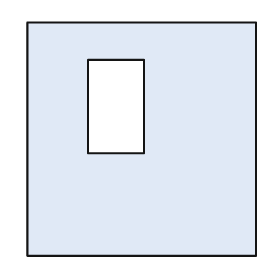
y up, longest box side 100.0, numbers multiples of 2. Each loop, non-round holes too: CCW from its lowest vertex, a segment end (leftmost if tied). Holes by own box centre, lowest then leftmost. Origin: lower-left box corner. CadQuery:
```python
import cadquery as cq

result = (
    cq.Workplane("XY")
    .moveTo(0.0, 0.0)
    .lineTo(98.0, 0.0)
    .lineTo(98.0, 100.0)
    .lineTo(0.0, 100.0)
    .close()
    .moveTo(26.0, 44.0)
    .lineTo(50.0, 44.0)
    .lineTo(50.0, 84.0)
    .lineTo(26.0, 84.0)
    .close()
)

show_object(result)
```